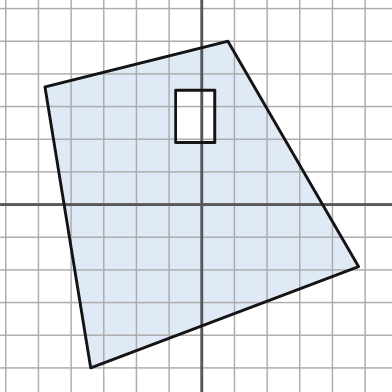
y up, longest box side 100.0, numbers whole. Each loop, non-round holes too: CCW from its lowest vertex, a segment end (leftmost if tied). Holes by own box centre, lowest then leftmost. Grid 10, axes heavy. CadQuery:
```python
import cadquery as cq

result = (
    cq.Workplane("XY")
    .moveTo(-34.0, -50.0)
    .lineTo(48.0, -19.0)
    .lineTo(8.0, 50.0)
    .lineTo(-48.0, 36.0)
    .close()
    .moveTo(-8.0, 19.0)
    .lineTo(4.0, 19.0)
    .lineTo(4.0, 35.0)
    .lineTo(-8.0, 35.0)
    .close()
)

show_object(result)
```